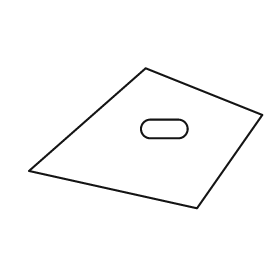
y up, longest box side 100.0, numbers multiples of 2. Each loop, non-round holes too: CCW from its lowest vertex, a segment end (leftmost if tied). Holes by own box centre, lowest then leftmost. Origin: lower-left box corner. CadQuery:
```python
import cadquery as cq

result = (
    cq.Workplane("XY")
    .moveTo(72.0, 0.0)
    .lineTo(100.0, 40.0)
    .lineTo(50.0, 60.0)
    .lineTo(0.0, 16.0)
    .close()
    .moveTo(52.0, 30.0)
    .lineTo(64.0, 30.0)
    .threePointArc((68.0, 34.0), (64.0, 38.0))
    .lineTo(52.0, 38.0)
    .threePointArc((48.0, 34.0), (52.0, 30.0))
    .close()
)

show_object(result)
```